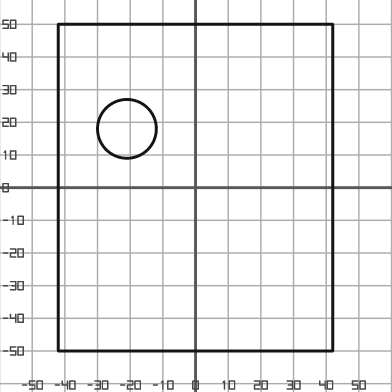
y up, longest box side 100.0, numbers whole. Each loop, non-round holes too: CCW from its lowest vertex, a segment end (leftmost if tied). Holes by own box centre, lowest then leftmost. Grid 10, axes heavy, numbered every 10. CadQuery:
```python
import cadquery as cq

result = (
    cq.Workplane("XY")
    .moveTo(-42.0, -50.0)
    .lineTo(42.0, -50.0)
    .lineTo(42.0, 50.0)
    .lineTo(-42.0, 50.0)
    .close()
    .moveTo(-21.0, 18.0)
    .circle(9.0)
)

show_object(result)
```